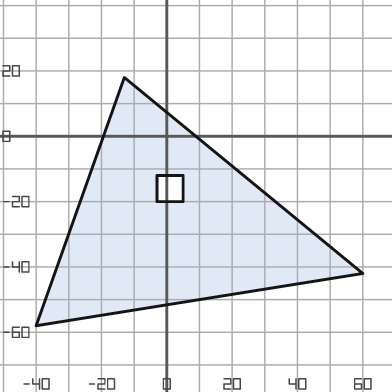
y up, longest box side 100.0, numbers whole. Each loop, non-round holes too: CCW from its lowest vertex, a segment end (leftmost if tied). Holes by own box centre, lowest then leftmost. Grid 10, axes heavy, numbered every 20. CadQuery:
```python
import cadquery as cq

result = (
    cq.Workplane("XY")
    .moveTo(-40.0, -58.0)
    .lineTo(60.0, -42.0)
    .lineTo(-13.0, 18.0)
    .close()
    .moveTo(-3.0, -20.0)
    .lineTo(5.0, -20.0)
    .lineTo(5.0, -12.0)
    .lineTo(-3.0, -12.0)
    .close()
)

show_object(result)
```